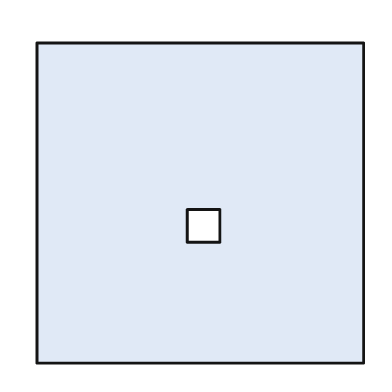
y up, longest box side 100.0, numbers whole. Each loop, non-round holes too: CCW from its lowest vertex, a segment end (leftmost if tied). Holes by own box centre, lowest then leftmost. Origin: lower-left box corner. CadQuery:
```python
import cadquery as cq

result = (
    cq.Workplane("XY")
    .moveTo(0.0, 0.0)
    .lineTo(100.0, 0.0)
    .lineTo(100.0, 98.0)
    .lineTo(0.0, 98.0)
    .close()
    .moveTo(46.0, 37.0)
    .lineTo(56.0, 37.0)
    .lineTo(56.0, 47.0)
    .lineTo(46.0, 47.0)
    .close()
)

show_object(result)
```